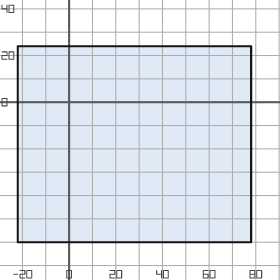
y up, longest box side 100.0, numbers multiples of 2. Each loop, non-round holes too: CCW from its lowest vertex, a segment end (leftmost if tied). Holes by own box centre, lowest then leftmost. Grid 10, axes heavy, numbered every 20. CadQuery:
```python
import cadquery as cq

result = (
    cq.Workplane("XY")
    .moveTo(-22.0, -60.0)
    .lineTo(78.0, -60.0)
    .lineTo(78.0, 24.0)
    .lineTo(-22.0, 24.0)
    .close()
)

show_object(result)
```